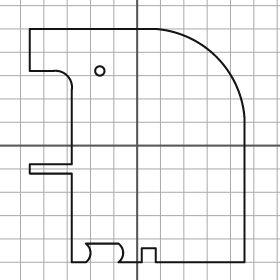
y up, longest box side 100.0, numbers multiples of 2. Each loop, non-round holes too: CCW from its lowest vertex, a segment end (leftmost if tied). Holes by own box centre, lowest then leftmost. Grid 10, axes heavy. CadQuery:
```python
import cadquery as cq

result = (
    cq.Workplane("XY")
    .moveTo(-28.0, -50.0)
    .lineTo(-22.0, -50.0)
    .threePointArc((-20.0, -46.0), (-22.0, -42.0))
    .lineTo(-8.0, -42.0)
    .threePointArc((-6.0, -46.0), (-8.0, -50.0))
    .lineTo(2.0, -50.0)
    .lineTo(2.0, -44.0)
    .lineTo(8.0, -44.0)
    .lineTo(8.0, -50.0)
    .lineTo(46.0, -50.0)
    .lineTo(46.0, 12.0)
    .threePointArc((34.0, 38.0), (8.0, 50.0))
    .lineTo(-46.0, 50.0)
    .lineTo(-46.0, 32.0)
    .lineTo(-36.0, 32.0)
    .threePointArc((-30.0, 30.0), (-28.0, 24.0))
    .lineTo(-28.0, -8.0)
    .lineTo(-46.0, -8.0)
    .lineTo(-46.0, -12.0)
    .lineTo(-28.0, -12.0)
    .close()
    .moveTo(-16.0, 32.0)
    .circle(2.0)
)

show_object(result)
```